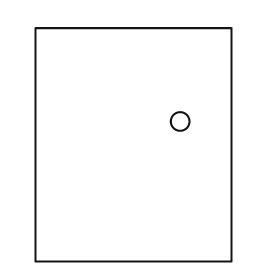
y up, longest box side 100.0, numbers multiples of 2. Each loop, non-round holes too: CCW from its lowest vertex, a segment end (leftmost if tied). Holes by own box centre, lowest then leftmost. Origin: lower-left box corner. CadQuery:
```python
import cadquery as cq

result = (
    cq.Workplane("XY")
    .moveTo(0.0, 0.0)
    .lineTo(84.0, 0.0)
    .lineTo(84.0, 100.0)
    .lineTo(0.0, 100.0)
    .close()
    .moveTo(62.0, 60.0)
    .circle(4.0)
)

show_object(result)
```